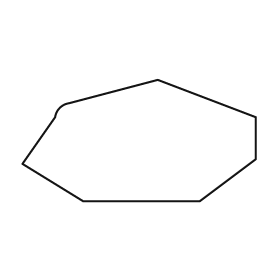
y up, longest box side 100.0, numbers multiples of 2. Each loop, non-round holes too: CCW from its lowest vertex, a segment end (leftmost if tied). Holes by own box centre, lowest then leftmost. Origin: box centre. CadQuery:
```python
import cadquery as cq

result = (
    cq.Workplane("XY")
    .moveTo(-24.0, -26.0)
    .lineTo(26.0, -26.0)
    .lineTo(50.0, -8.0)
    .lineTo(50.0, 10.0)
    .lineTo(8.0, 26.0)
    .lineTo(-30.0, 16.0)
    .threePointArc((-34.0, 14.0), (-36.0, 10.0))
    .lineTo(-50.0, -10.0)
    .close()
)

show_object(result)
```